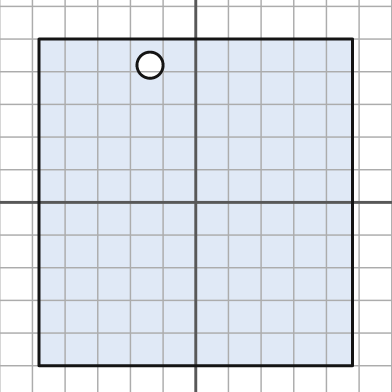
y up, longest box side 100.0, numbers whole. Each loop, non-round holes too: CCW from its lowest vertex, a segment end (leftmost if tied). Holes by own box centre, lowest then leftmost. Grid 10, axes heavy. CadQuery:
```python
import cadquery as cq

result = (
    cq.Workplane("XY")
    .moveTo(-48.0, -50.0)
    .lineTo(48.0, -50.0)
    .lineTo(48.0, 50.0)
    .lineTo(-48.0, 50.0)
    .close()
    .moveTo(-14.0, 42.0)
    .circle(4.0)
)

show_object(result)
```